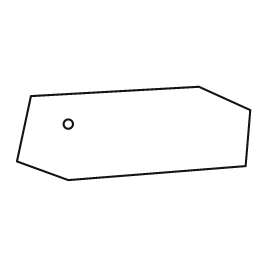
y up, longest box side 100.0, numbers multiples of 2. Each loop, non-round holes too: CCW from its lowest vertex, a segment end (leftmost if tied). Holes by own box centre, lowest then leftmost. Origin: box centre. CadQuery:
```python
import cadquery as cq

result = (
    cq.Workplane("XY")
    .moveTo(-28.0, -20.0)
    .lineTo(48.0, -14.0)
    .lineTo(50.0, 10.0)
    .lineTo(28.0, 20.0)
    .lineTo(-44.0, 16.0)
    .lineTo(-50.0, -12.0)
    .close()
    .moveTo(-28.0, 4.0)
    .circle(2.0)
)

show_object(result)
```